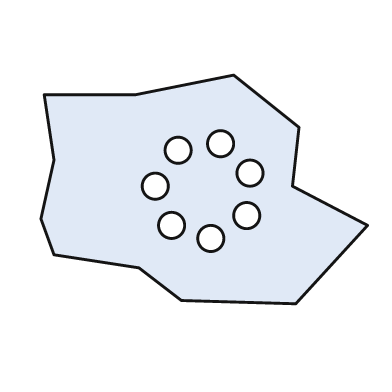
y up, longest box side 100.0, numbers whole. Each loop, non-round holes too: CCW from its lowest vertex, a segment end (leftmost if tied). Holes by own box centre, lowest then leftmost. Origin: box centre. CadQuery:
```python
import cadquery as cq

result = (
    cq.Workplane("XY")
    .moveTo(28.0, -35.0)
    .lineTo(50.0, -11.0)
    .lineTo(27.0, 1.0)
    .lineTo(29.0, 19.0)
    .lineTo(9.0, 35.0)
    .lineTo(-21.0, 29.0)
    .lineTo(-49.0, 29.0)
    .lineTo(-46.0, 9.0)
    .lineTo(-50.0, -9.0)
    .lineTo(-46.0, -20.0)
    .lineTo(-20.0, -24.0)
    .lineTo(-7.0, -34.0)
    .close()
    .moveTo(2.0, -15.0)
    .circle(4.0)
    .moveTo(-10.0, -11.0)
    .circle(4.0)
    .moveTo(13.0, -8.0)
    .circle(4.0)
    .moveTo(-15.0, 1.0)
    .circle(4.0)
    .moveTo(14.0, 5.0)
    .circle(4.0)
    .moveTo(-8.0, 12.0)
    .circle(4.0)
    .moveTo(5.0, 14.0)
    .circle(4.0)
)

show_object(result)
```